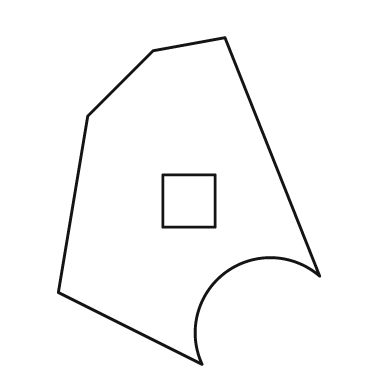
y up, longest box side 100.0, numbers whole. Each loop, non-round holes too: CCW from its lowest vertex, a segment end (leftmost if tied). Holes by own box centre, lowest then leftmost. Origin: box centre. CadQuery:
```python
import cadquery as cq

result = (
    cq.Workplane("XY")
    .moveTo(4.0, -50.0)
    .threePointArc((11.0, -22.0), (40.0, -23.0))
    .lineTo(11.0, 50.0)
    .lineTo(-11.0, 46.0)
    .lineTo(-31.0, 26.0)
    .lineTo(-40.0, -28.0)
    .close()
    .moveTo(-8.0, -8.0)
    .lineTo(8.0, -8.0)
    .lineTo(8.0, 8.0)
    .lineTo(-8.0, 8.0)
    .close()
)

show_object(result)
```